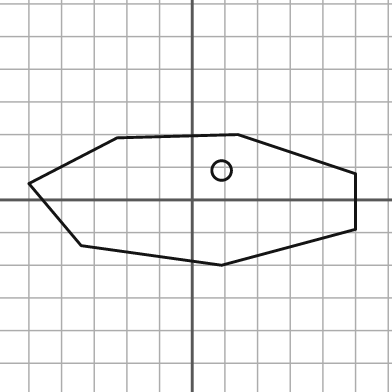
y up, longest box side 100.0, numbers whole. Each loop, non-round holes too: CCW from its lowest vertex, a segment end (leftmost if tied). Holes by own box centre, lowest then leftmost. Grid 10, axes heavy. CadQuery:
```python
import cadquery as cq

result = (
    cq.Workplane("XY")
    .moveTo(9.0, -20.0)
    .lineTo(50.0, -9.0)
    .lineTo(50.0, 8.0)
    .lineTo(14.0, 20.0)
    .lineTo(-23.0, 19.0)
    .lineTo(-50.0, 5.0)
    .lineTo(-34.0, -14.0)
    .close()
    .moveTo(9.0, 9.0)
    .circle(3.0)
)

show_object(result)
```